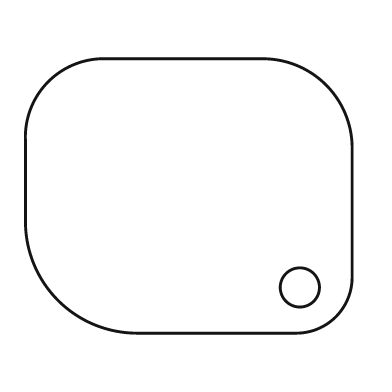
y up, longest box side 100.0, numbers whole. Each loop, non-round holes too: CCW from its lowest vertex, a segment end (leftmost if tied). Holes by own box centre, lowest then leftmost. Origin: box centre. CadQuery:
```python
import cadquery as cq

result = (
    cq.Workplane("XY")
    .moveTo(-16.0, -42.0)
    .lineTo(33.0, -42.0)
    .threePointArc((45.0, -37.0), (50.0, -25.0))
    .lineTo(50.0, 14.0)
    .threePointArc((42.0, 34.0), (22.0, 42.0))
    .lineTo(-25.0, 42.0)
    .threePointArc((-43.0, 35.0), (-50.0, 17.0))
    .lineTo(-50.0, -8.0)
    .threePointArc((-40.0, -32.0), (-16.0, -42.0))
    .close()
    .moveTo(34.0, -28.0)
    .circle(6.0)
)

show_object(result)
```